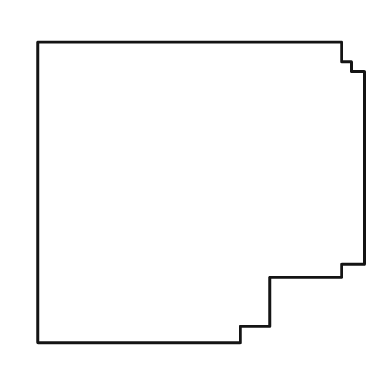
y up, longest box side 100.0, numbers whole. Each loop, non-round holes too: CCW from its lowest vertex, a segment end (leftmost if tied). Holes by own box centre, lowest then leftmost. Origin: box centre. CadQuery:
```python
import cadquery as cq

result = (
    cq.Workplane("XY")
    .moveTo(-50.0, -46.0)
    .lineTo(12.0, -46.0)
    .lineTo(12.0, -41.0)
    .lineTo(21.0, -41.0)
    .lineTo(21.0, -26.0)
    .lineTo(43.0, -26.0)
    .lineTo(43.0, -22.0)
    .lineTo(50.0, -22.0)
    .lineTo(50.0, 37.0)
    .lineTo(46.0, 37.0)
    .lineTo(46.0, 40.0)
    .lineTo(43.0, 40.0)
    .lineTo(43.0, 46.0)
    .lineTo(-50.0, 46.0)
    .close()
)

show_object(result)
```